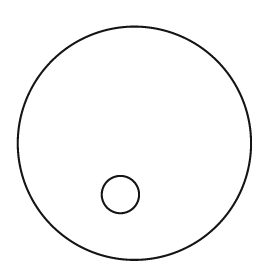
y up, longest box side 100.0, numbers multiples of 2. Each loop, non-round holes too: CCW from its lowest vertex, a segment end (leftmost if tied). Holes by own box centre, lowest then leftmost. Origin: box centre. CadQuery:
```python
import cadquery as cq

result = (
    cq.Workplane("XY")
    .moveTo(0.0, 0.0)
    .circle(50.0)
    .moveTo(-6.0, -22.0)
    .circle(8.0)
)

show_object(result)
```